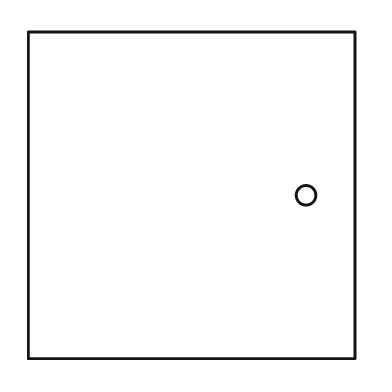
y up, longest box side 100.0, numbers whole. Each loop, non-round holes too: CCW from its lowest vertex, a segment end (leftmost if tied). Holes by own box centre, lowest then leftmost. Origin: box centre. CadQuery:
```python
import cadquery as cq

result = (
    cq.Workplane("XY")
    .moveTo(-50.0, -50.0)
    .lineTo(50.0, -50.0)
    .lineTo(50.0, 50.0)
    .lineTo(-50.0, 50.0)
    .close()
    .moveTo(35.0, 0.0)
    .circle(3.0)
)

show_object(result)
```